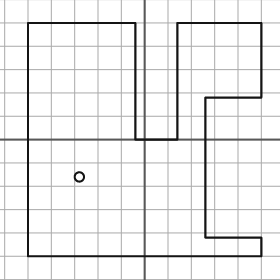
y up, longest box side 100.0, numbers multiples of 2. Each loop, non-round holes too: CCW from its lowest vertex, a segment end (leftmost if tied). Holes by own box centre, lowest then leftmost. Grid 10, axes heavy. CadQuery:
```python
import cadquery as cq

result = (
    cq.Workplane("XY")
    .moveTo(-50.0, -50.0)
    .lineTo(50.0, -50.0)
    .lineTo(50.0, -42.0)
    .lineTo(26.0, -42.0)
    .lineTo(26.0, 18.0)
    .lineTo(50.0, 18.0)
    .lineTo(50.0, 50.0)
    .lineTo(14.0, 50.0)
    .lineTo(14.0, 0.0)
    .lineTo(-4.0, 0.0)
    .lineTo(-4.0, 50.0)
    .lineTo(-50.0, 50.0)
    .close()
    .moveTo(-28.0, -16.0)
    .circle(2.0)
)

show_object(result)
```